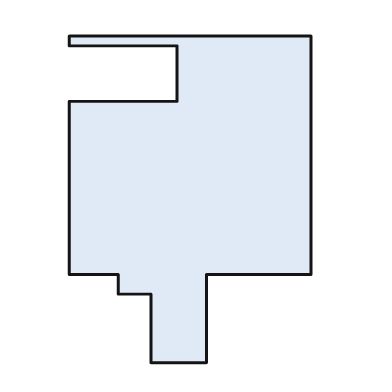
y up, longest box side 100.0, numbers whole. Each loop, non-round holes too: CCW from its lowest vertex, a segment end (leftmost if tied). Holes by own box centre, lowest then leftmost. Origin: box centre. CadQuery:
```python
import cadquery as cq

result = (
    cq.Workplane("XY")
    .moveTo(-12.0, -50.0)
    .lineTo(5.0, -50.0)
    .lineTo(5.0, -23.0)
    .lineTo(37.0, -23.0)
    .lineTo(37.0, 50.0)
    .lineTo(-37.0, 50.0)
    .lineTo(-37.0, 47.0)
    .lineTo(-4.0, 47.0)
    .lineTo(-4.0, 30.0)
    .lineTo(-37.0, 30.0)
    .lineTo(-37.0, -23.0)
    .lineTo(-22.0, -23.0)
    .lineTo(-22.0, -29.0)
    .lineTo(-12.0, -29.0)
    .close()
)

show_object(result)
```